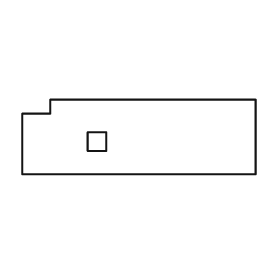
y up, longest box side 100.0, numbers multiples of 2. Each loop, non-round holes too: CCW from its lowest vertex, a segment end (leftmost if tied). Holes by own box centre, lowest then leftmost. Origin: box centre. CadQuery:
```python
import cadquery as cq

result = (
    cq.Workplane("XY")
    .moveTo(-50.0, -16.0)
    .lineTo(50.0, -16.0)
    .lineTo(50.0, 16.0)
    .lineTo(-38.0, 16.0)
    .lineTo(-38.0, 10.0)
    .lineTo(-50.0, 10.0)
    .close()
    .moveTo(-22.0, -6.0)
    .lineTo(-14.0, -6.0)
    .lineTo(-14.0, 2.0)
    .lineTo(-22.0, 2.0)
    .close()
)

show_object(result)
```